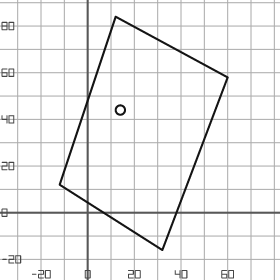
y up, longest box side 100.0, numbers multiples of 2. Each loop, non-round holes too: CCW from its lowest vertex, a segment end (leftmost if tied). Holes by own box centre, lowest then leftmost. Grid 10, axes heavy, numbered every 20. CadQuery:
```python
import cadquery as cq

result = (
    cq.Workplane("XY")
    .moveTo(32.0, -16.0)
    .lineTo(60.0, 58.0)
    .lineTo(12.0, 84.0)
    .lineTo(-12.0, 12.0)
    .close()
    .moveTo(14.0, 44.0)
    .circle(2.0)
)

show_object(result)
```